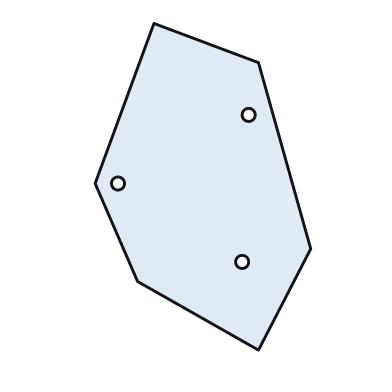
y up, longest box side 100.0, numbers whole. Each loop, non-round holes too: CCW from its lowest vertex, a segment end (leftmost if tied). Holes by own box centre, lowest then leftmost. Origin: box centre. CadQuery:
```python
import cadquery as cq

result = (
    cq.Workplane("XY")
    .moveTo(17.0, -50.0)
    .lineTo(33.0, -19.0)
    .lineTo(17.0, 38.0)
    .lineTo(-15.0, 50.0)
    .lineTo(-33.0, 1.0)
    .lineTo(-20.0, -29.0)
    .close()
    .moveTo(12.0, -23.0)
    .circle(2.0)
    .moveTo(-26.0, 1.0)
    .circle(2.0)
    .moveTo(14.0, 22.0)
    .circle(2.0)
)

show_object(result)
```